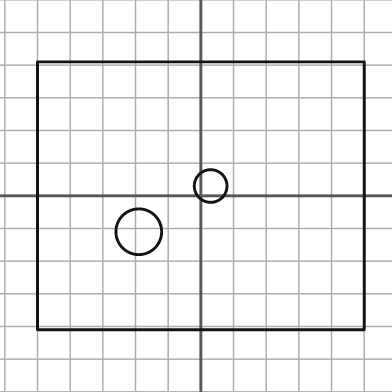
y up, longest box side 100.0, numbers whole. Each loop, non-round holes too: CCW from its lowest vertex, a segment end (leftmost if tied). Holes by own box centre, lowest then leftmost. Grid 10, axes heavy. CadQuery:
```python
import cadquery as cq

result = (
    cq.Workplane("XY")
    .moveTo(-50.0, -41.0)
    .lineTo(50.0, -41.0)
    .lineTo(50.0, 41.0)
    .lineTo(-50.0, 41.0)
    .close()
    .moveTo(-19.0, -11.0)
    .circle(7.0)
    .moveTo(3.0, 3.0)
    .circle(5.0)
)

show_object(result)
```